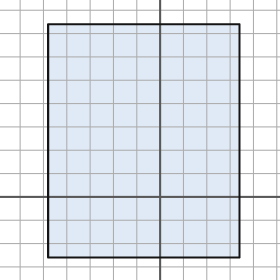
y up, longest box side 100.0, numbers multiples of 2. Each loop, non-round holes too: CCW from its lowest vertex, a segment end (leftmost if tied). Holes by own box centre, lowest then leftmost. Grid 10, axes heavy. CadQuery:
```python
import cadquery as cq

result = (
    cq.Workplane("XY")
    .moveTo(-48.0, -26.0)
    .lineTo(34.0, -26.0)
    .lineTo(34.0, 74.0)
    .lineTo(-48.0, 74.0)
    .close()
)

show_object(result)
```